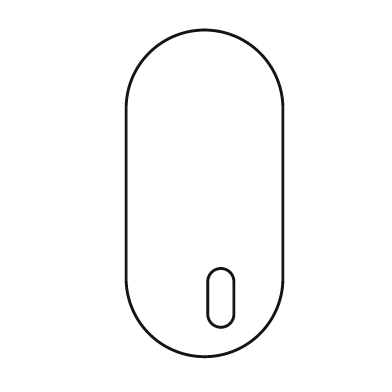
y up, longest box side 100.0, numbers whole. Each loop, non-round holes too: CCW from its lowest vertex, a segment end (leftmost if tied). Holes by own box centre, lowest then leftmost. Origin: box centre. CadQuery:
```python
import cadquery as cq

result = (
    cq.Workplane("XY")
    .moveTo(-24.0, -26.0)
    .threePointArc((0.0, -50.0), (24.0, -26.0))
    .lineTo(24.0, 26.0)
    .threePointArc((0.0, 50.0), (-24.0, 26.0))
    .close()
    .moveTo(1.0, -37.0)
    .threePointArc((5.0, -41.0), (9.0, -37.0))
    .lineTo(9.0, -27.0)
    .threePointArc((5.0, -23.0), (1.0, -27.0))
    .close()
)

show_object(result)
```